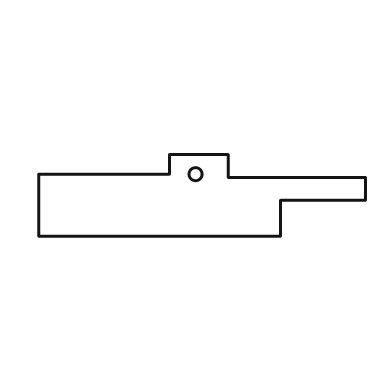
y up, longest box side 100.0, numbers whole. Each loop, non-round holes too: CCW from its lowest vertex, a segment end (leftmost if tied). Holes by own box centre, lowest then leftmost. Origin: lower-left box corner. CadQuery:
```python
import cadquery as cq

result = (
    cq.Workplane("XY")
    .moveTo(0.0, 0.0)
    .lineTo(74.0, 0.0)
    .lineTo(74.0, 11.0)
    .lineTo(100.0, 11.0)
    .lineTo(100.0, 18.0)
    .lineTo(58.0, 18.0)
    .lineTo(58.0, 25.0)
    .lineTo(40.0, 25.0)
    .lineTo(40.0, 19.0)
    .lineTo(0.0, 19.0)
    .close()
    .moveTo(48.0, 19.0)
    .circle(2.0)
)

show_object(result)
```